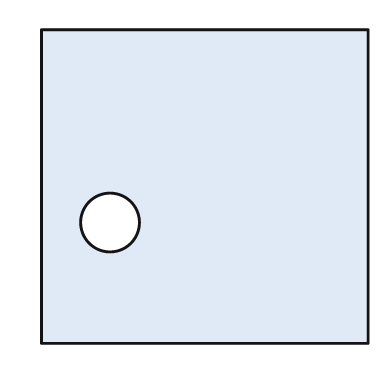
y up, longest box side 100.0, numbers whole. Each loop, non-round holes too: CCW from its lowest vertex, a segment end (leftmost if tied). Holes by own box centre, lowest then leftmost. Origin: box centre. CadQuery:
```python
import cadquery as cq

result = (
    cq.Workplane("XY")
    .moveTo(-50.0, -48.0)
    .lineTo(50.0, -48.0)
    .lineTo(50.0, 48.0)
    .lineTo(-50.0, 48.0)
    .close()
    .moveTo(-29.0, -11.0)
    .circle(9.0)
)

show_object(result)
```